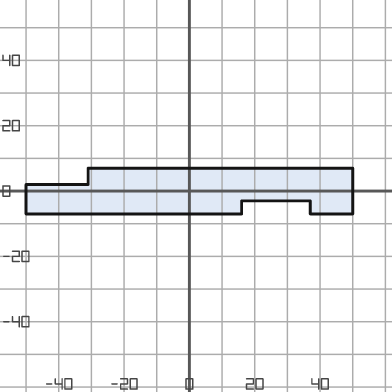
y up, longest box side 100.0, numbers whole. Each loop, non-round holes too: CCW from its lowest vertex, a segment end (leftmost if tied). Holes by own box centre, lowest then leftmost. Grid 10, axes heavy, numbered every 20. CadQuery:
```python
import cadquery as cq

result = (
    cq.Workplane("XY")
    .moveTo(-50.0, -7.0)
    .lineTo(16.0, -7.0)
    .lineTo(16.0, -3.0)
    .lineTo(37.0, -3.0)
    .lineTo(37.0, -7.0)
    .lineTo(50.0, -7.0)
    .lineTo(50.0, 7.0)
    .lineTo(-31.0, 7.0)
    .lineTo(-31.0, 2.0)
    .lineTo(-50.0, 2.0)
    .close()
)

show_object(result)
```